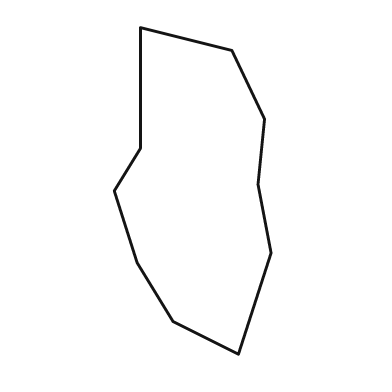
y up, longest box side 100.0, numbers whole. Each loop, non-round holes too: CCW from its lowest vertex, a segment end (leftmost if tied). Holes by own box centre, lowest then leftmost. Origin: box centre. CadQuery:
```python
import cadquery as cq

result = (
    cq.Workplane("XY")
    .moveTo(14.0, -50.0)
    .lineTo(24.0, -19.0)
    .lineTo(20.0, 2.0)
    .lineTo(22.0, 22.0)
    .lineTo(12.0, 43.0)
    .lineTo(-16.0, 50.0)
    .lineTo(-16.0, 13.0)
    .lineTo(-24.0, 0.0)
    .lineTo(-17.0, -22.0)
    .lineTo(-6.0, -40.0)
    .close()
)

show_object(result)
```